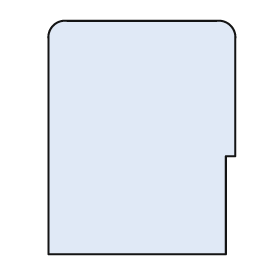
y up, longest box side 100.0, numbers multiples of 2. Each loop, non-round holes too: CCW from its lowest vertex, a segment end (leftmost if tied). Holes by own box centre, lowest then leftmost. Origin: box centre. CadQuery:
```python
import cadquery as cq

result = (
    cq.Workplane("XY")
    .moveTo(-40.0, -50.0)
    .lineTo(36.0, -50.0)
    .lineTo(36.0, -8.0)
    .lineTo(40.0, -8.0)
    .lineTo(40.0, 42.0)
    .threePointArc((38.0, 48.0), (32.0, 50.0))
    .lineTo(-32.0, 50.0)
    .threePointArc((-38.0, 48.0), (-40.0, 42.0))
    .close()
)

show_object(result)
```